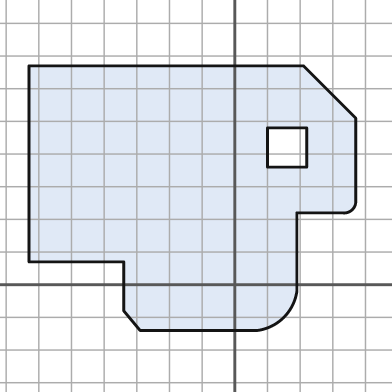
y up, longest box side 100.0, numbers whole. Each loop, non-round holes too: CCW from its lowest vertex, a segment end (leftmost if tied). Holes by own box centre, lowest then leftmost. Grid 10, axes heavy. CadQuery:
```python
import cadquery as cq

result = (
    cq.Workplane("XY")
    .moveTo(-29.0, -14.0)
    .lineTo(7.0, -14.0)
    .threePointArc((15.0, -10.0), (19.0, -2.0))
    .lineTo(19.0, 22.0)
    .lineTo(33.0, 22.0)
    .threePointArc((36.0, 23.0), (37.0, 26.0))
    .lineTo(37.0, 51.0)
    .lineTo(21.0, 67.0)
    .lineTo(-63.0, 67.0)
    .lineTo(-63.0, 7.0)
    .lineTo(-34.0, 7.0)
    .lineTo(-34.0, -8.0)
    .close()
    .moveTo(10.0, 36.0)
    .lineTo(22.0, 36.0)
    .lineTo(22.0, 48.0)
    .lineTo(10.0, 48.0)
    .close()
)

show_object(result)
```